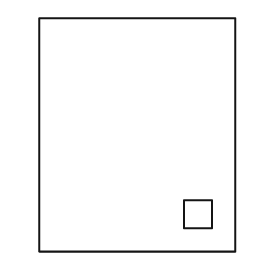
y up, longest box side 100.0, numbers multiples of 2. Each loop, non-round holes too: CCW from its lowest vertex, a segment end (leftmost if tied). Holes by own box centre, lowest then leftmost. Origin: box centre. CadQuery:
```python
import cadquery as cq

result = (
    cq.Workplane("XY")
    .moveTo(-42.0, -50.0)
    .lineTo(42.0, -50.0)
    .lineTo(42.0, 50.0)
    .lineTo(-42.0, 50.0)
    .close()
    .moveTo(20.0, -40.0)
    .lineTo(32.0, -40.0)
    .lineTo(32.0, -28.0)
    .lineTo(20.0, -28.0)
    .close()
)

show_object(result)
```